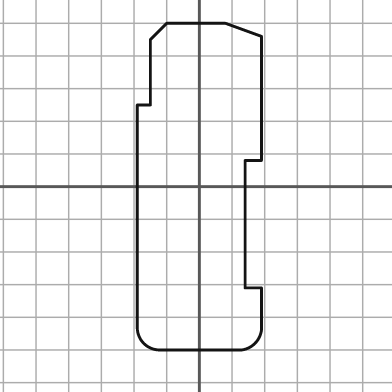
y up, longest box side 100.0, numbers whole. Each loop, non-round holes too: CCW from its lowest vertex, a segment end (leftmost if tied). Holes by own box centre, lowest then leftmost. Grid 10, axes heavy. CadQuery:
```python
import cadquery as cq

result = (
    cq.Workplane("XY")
    .moveTo(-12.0, -50.0)
    .lineTo(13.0, -50.0)
    .threePointArc((17.0, -48.0), (19.0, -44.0))
    .lineTo(19.0, -31.0)
    .lineTo(14.0, -31.0)
    .lineTo(14.0, 8.0)
    .lineTo(19.0, 8.0)
    .lineTo(19.0, 46.0)
    .lineTo(8.0, 50.0)
    .lineTo(-10.0, 50.0)
    .lineTo(-15.0, 45.0)
    .lineTo(-15.0, 25.0)
    .lineTo(-19.0, 25.0)
    .lineTo(-19.0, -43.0)
    .threePointArc((-17.0, -48.0), (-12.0, -50.0))
    .close()
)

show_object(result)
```